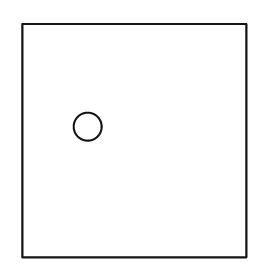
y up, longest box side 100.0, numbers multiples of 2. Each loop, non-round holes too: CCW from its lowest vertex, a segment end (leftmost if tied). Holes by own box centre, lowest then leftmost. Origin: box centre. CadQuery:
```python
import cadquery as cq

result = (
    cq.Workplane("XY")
    .moveTo(-48.0, -50.0)
    .lineTo(48.0, -50.0)
    .lineTo(48.0, 50.0)
    .lineTo(-48.0, 50.0)
    .close()
    .moveTo(-20.0, 6.0)
    .circle(6.0)
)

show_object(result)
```